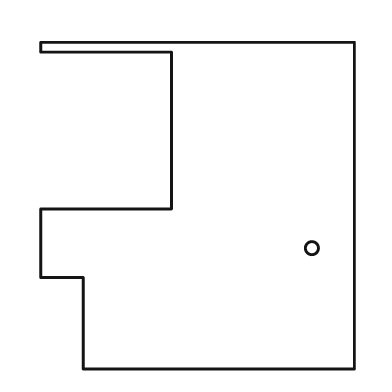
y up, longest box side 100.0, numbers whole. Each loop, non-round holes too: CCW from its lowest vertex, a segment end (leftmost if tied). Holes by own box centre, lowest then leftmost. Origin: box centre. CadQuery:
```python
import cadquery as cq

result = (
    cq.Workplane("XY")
    .moveTo(-35.0, -50.0)
    .lineTo(48.0, -50.0)
    .lineTo(48.0, 50.0)
    .lineTo(-48.0, 50.0)
    .lineTo(-48.0, 47.0)
    .lineTo(-8.0, 47.0)
    .lineTo(-8.0, -1.0)
    .lineTo(-48.0, -1.0)
    .lineTo(-48.0, -22.0)
    .lineTo(-35.0, -22.0)
    .close()
    .moveTo(35.0, -13.0)
    .circle(2.0)
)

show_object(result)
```